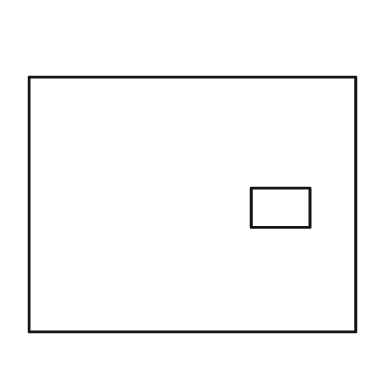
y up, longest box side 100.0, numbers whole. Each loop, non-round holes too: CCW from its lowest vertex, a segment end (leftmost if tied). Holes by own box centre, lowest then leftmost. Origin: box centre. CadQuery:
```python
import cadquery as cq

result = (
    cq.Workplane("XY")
    .moveTo(-50.0, -39.0)
    .lineTo(50.0, -39.0)
    .lineTo(50.0, 39.0)
    .lineTo(-50.0, 39.0)
    .close()
    .moveTo(18.0, -7.0)
    .lineTo(36.0, -7.0)
    .lineTo(36.0, 5.0)
    .lineTo(18.0, 5.0)
    .close()
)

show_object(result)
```